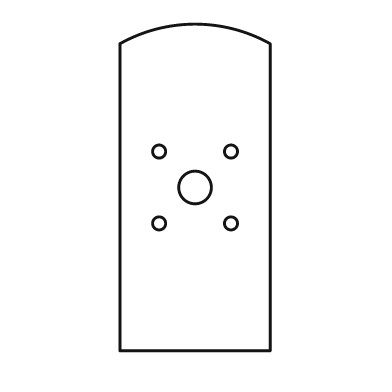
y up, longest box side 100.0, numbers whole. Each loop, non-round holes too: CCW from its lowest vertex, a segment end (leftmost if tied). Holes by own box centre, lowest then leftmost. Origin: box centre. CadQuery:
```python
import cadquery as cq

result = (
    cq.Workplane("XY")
    .moveTo(-23.0, -50.0)
    .lineTo(23.0, -50.0)
    .lineTo(23.0, 44.0)
    .threePointArc((0.0, 50.0), (-23.0, 44.0))
    .close()
    .moveTo(-11.0, -11.0)
    .circle(2.0)
    .moveTo(11.0, -11.0)
    .circle(2.0)
    .moveTo(0.0, 0.0)
    .circle(5.0)
    .moveTo(-11.0, 11.0)
    .circle(2.0)
    .moveTo(11.0, 11.0)
    .circle(2.0)
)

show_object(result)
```